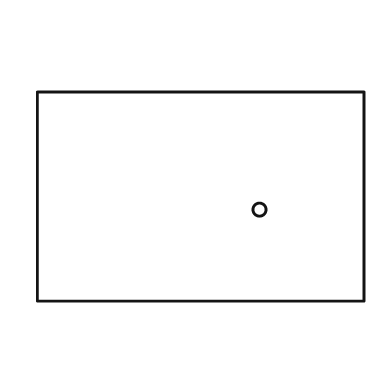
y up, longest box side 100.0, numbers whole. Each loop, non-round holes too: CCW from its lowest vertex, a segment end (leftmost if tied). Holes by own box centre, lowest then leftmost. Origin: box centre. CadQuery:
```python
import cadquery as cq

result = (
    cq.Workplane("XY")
    .moveTo(-50.0, -32.0)
    .lineTo(50.0, -32.0)
    .lineTo(50.0, 32.0)
    .lineTo(-50.0, 32.0)
    .close()
    .moveTo(18.0, -4.0)
    .circle(2.0)
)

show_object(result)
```